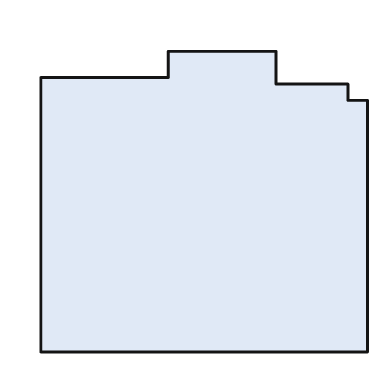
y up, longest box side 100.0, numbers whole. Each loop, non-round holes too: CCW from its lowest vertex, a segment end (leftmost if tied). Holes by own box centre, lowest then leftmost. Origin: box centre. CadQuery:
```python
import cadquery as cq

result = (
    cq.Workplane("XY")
    .moveTo(-50.0, -46.0)
    .lineTo(50.0, -46.0)
    .lineTo(50.0, 31.0)
    .lineTo(44.0, 31.0)
    .lineTo(44.0, 36.0)
    .lineTo(22.0, 36.0)
    .lineTo(22.0, 46.0)
    .lineTo(-11.0, 46.0)
    .lineTo(-11.0, 38.0)
    .lineTo(-50.0, 38.0)
    .close()
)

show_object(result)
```